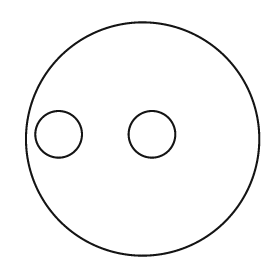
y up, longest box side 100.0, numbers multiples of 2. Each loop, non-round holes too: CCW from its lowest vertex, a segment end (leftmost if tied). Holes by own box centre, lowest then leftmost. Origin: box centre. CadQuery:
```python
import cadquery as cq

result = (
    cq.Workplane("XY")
    .moveTo(0.0, 0.0)
    .circle(50.0)
    .moveTo(-36.0, 2.0)
    .circle(10.0)
    .moveTo(4.0, 2.0)
    .circle(10.0)
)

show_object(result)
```